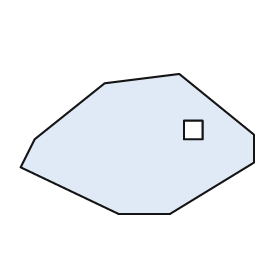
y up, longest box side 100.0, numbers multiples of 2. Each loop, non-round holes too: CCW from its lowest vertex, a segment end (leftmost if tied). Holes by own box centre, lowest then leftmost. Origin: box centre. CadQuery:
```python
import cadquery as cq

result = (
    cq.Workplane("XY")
    .moveTo(-8.0, -30.0)
    .lineTo(14.0, -30.0)
    .lineTo(50.0, -8.0)
    .lineTo(50.0, 4.0)
    .lineTo(18.0, 30.0)
    .lineTo(-14.0, 26.0)
    .lineTo(-44.0, 2.0)
    .lineTo(-50.0, -10.0)
    .close()
    .moveTo(20.0, 2.0)
    .lineTo(28.0, 2.0)
    .lineTo(28.0, 10.0)
    .lineTo(20.0, 10.0)
    .close()
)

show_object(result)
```